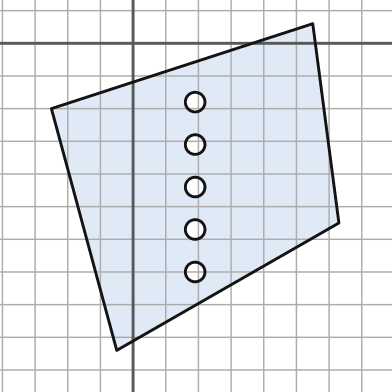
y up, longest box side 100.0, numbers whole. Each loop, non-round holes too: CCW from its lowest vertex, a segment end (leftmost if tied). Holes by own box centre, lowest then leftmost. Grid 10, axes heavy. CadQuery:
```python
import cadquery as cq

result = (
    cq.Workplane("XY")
    .moveTo(-5.0, -94.0)
    .lineTo(63.0, -55.0)
    .lineTo(55.0, 6.0)
    .lineTo(-25.0, -20.0)
    .close()
    .moveTo(19.0, -70.0)
    .circle(3.0)
    .moveTo(19.0, -57.0)
    .circle(3.0)
    .moveTo(19.0, -44.0)
    .circle(3.0)
    .moveTo(19.0, -31.0)
    .circle(3.0)
    .moveTo(19.0, -18.0)
    .circle(3.0)
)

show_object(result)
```